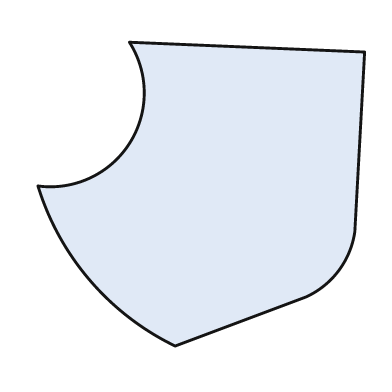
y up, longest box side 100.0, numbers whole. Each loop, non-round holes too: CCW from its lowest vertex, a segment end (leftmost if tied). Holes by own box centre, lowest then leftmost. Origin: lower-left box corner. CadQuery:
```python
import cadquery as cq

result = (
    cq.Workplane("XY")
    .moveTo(42.0, 0.0)
    .lineTo(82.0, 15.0)
    .threePointArc((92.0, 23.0), (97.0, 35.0))
    .lineTo(100.0, 90.0)
    .lineTo(28.0, 93.0)
    .threePointArc((28.0, 62.0), (0.0, 49.0))
    .threePointArc((16.0, 20.0), (42.0, 0.0))
    .close()
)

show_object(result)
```